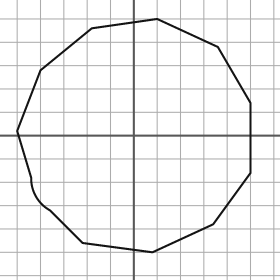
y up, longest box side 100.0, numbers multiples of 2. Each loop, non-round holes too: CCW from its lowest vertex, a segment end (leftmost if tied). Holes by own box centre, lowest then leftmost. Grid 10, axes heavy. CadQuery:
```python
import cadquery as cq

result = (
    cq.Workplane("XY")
    .moveTo(8.0, -50.0)
    .lineTo(34.0, -38.0)
    .lineTo(50.0, -16.0)
    .lineTo(50.0, 14.0)
    .lineTo(36.0, 38.0)
    .lineTo(10.0, 50.0)
    .lineTo(-18.0, 46.0)
    .lineTo(-40.0, 28.0)
    .lineTo(-50.0, 2.0)
    .lineTo(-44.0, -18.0)
    .threePointArc((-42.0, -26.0), (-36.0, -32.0))
    .lineTo(-22.0, -46.0)
    .close()
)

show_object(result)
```